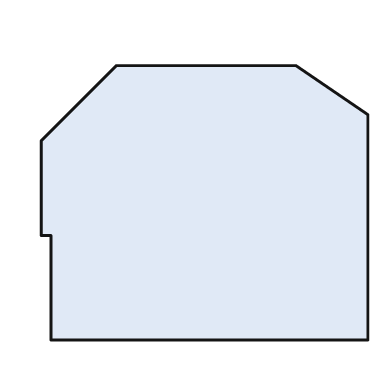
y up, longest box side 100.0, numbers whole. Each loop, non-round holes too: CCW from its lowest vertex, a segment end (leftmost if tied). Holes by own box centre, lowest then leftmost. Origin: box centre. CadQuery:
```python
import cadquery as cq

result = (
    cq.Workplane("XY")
    .moveTo(-47.0, -42.0)
    .lineTo(50.0, -42.0)
    .lineTo(50.0, 27.0)
    .lineTo(28.0, 42.0)
    .lineTo(-27.0, 42.0)
    .lineTo(-50.0, 19.0)
    .lineTo(-50.0, -10.0)
    .lineTo(-47.0, -10.0)
    .close()
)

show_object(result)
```